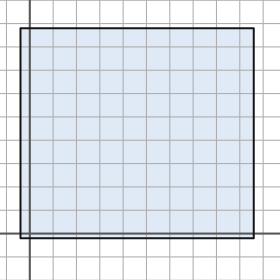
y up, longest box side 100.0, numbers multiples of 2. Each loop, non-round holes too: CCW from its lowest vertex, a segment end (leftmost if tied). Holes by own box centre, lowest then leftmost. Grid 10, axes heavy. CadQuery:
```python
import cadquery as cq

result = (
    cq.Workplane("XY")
    .moveTo(-4.0, -2.0)
    .lineTo(96.0, -2.0)
    .lineTo(96.0, 88.0)
    .lineTo(-4.0, 88.0)
    .close()
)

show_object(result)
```